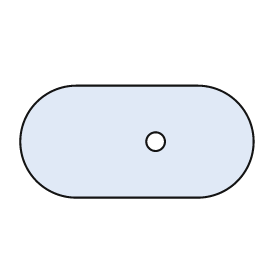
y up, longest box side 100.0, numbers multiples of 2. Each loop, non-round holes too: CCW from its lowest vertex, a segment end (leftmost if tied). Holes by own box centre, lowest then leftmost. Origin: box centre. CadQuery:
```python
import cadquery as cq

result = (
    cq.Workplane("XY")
    .moveTo(-26.0, -24.0)
    .lineTo(26.0, -24.0)
    .threePointArc((50.0, 0.0), (26.0, 24.0))
    .lineTo(-26.0, 24.0)
    .threePointArc((-50.0, 0.0), (-26.0, -24.0))
    .close()
    .moveTo(8.0, 0.0)
    .circle(4.0)
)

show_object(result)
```